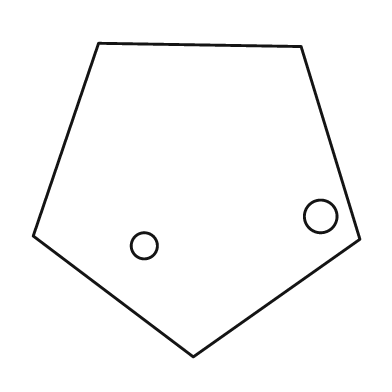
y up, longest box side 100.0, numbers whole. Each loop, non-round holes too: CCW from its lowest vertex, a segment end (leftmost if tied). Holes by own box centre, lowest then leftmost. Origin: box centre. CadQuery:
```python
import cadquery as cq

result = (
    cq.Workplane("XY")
    .moveTo(-1.0, -48.0)
    .lineTo(50.0, -12.0)
    .lineTo(32.0, 47.0)
    .lineTo(-30.0, 48.0)
    .lineTo(-50.0, -11.0)
    .close()
    .moveTo(-16.0, -14.0)
    .circle(4.0)
    .moveTo(38.0, -5.0)
    .circle(5.0)
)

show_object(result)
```